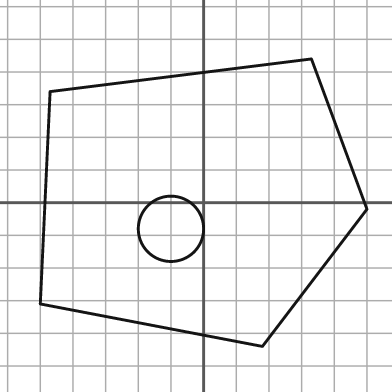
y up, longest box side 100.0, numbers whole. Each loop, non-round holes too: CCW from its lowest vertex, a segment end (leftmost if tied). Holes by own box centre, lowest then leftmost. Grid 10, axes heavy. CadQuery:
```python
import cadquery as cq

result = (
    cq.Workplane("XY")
    .moveTo(18.0, -44.0)
    .lineTo(50.0, -2.0)
    .lineTo(33.0, 44.0)
    .lineTo(-47.0, 34.0)
    .lineTo(-50.0, -31.0)
    .close()
    .moveTo(-10.0, -8.0)
    .circle(10.0)
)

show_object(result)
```